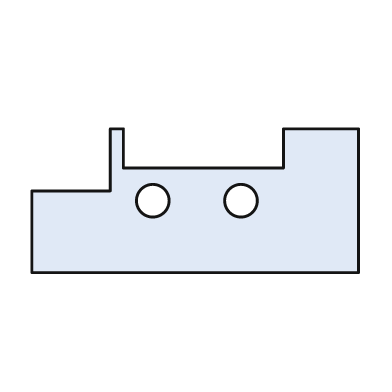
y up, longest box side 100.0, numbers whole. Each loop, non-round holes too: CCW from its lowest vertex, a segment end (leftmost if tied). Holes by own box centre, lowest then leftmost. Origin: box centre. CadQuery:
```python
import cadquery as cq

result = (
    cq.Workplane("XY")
    .moveTo(-50.0, -22.0)
    .lineTo(50.0, -22.0)
    .lineTo(50.0, 22.0)
    .lineTo(27.0, 22.0)
    .lineTo(27.0, 10.0)
    .lineTo(-22.0, 10.0)
    .lineTo(-22.0, 22.0)
    .lineTo(-26.0, 22.0)
    .lineTo(-26.0, 3.0)
    .lineTo(-50.0, 3.0)
    .close()
    .moveTo(-13.0, 0.0)
    .circle(5.0)
    .moveTo(14.0, 0.0)
    .circle(5.0)
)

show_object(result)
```